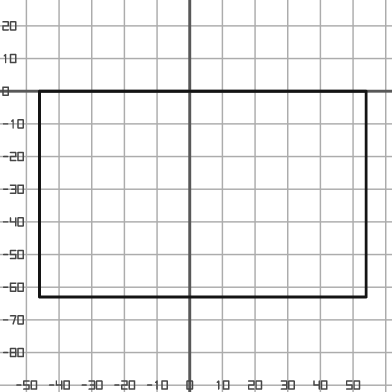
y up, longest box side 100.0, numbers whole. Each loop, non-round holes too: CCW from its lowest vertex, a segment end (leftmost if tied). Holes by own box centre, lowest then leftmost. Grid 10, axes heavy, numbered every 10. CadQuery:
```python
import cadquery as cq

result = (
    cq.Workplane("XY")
    .moveTo(-46.0, -63.0)
    .lineTo(54.0, -63.0)
    .lineTo(54.0, 0.0)
    .lineTo(-46.0, 0.0)
    .close()
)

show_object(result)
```